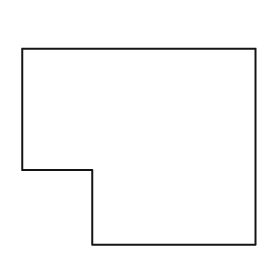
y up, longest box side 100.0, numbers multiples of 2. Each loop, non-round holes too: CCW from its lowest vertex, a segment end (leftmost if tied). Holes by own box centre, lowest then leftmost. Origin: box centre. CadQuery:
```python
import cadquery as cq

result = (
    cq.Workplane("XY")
    .moveTo(-20.0, -42.0)
    .lineTo(50.0, -42.0)
    .lineTo(50.0, 42.0)
    .lineTo(-50.0, 42.0)
    .lineTo(-50.0, -10.0)
    .lineTo(-20.0, -10.0)
    .close()
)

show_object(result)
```